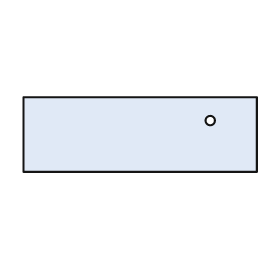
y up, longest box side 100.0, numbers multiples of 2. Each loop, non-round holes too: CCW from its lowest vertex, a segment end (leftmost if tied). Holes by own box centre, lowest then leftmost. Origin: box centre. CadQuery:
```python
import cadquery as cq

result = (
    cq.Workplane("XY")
    .moveTo(-50.0, -16.0)
    .lineTo(50.0, -16.0)
    .lineTo(50.0, 16.0)
    .lineTo(-50.0, 16.0)
    .close()
    .moveTo(30.0, 6.0)
    .circle(2.0)
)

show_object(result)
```